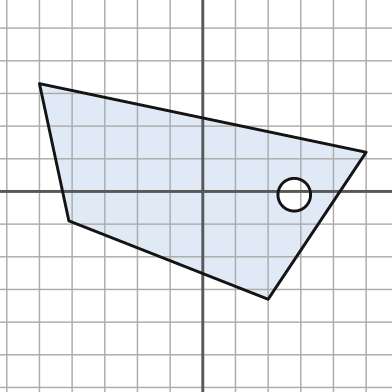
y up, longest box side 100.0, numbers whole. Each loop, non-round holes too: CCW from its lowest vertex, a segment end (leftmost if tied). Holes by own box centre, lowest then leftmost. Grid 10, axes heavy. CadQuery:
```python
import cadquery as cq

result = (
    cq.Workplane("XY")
    .moveTo(20.0, -33.0)
    .lineTo(50.0, 12.0)
    .lineTo(-50.0, 33.0)
    .lineTo(-41.0, -9.0)
    .close()
    .moveTo(28.0, -1.0)
    .circle(5.0)
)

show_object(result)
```